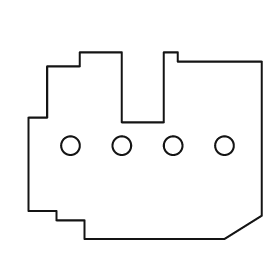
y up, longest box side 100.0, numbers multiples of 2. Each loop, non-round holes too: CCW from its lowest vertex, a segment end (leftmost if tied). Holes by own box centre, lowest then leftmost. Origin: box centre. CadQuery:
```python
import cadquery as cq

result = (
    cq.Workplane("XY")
    .moveTo(-26.0, -40.0)
    .lineTo(34.0, -40.0)
    .lineTo(50.0, -30.0)
    .lineTo(50.0, 36.0)
    .lineTo(14.0, 36.0)
    .lineTo(14.0, 40.0)
    .lineTo(8.0, 40.0)
    .lineTo(8.0, 10.0)
    .lineTo(-10.0, 10.0)
    .lineTo(-10.0, 40.0)
    .lineTo(-28.0, 40.0)
    .lineTo(-28.0, 34.0)
    .lineTo(-42.0, 34.0)
    .lineTo(-42.0, 12.0)
    .lineTo(-50.0, 12.0)
    .lineTo(-50.0, -28.0)
    .lineTo(-38.0, -28.0)
    .lineTo(-38.0, -32.0)
    .lineTo(-26.0, -32.0)
    .close()
    .moveTo(-32.0, 0.0)
    .circle(4.0)
    .moveTo(-10.0, 0.0)
    .circle(4.0)
    .moveTo(12.0, 0.0)
    .circle(4.0)
    .moveTo(34.0, 0.0)
    .circle(4.0)
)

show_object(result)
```